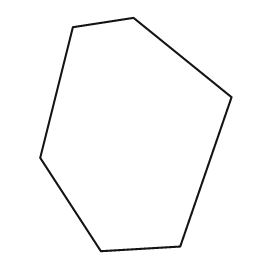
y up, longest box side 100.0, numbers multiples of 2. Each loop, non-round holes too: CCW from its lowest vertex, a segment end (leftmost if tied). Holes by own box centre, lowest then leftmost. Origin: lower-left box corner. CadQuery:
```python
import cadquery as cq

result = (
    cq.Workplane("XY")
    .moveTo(26.0, 0.0)
    .lineTo(60.0, 2.0)
    .lineTo(82.0, 66.0)
    .lineTo(40.0, 100.0)
    .lineTo(14.0, 96.0)
    .lineTo(0.0, 40.0)
    .close()
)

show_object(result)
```